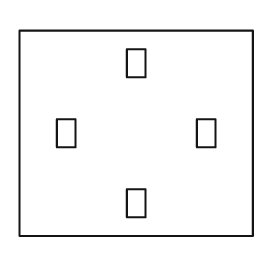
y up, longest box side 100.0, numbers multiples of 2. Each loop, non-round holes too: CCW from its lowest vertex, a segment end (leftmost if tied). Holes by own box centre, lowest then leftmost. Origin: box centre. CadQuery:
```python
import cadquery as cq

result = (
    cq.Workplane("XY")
    .moveTo(-50.0, -44.0)
    .lineTo(50.0, -44.0)
    .lineTo(50.0, 44.0)
    .lineTo(-50.0, 44.0)
    .close()
    .moveTo(-4.0, -36.0)
    .lineTo(4.0, -36.0)
    .lineTo(4.0, -24.0)
    .lineTo(-4.0, -24.0)
    .close()
    .moveTo(-34.0, -6.0)
    .lineTo(-26.0, -6.0)
    .lineTo(-26.0, 6.0)
    .lineTo(-34.0, 6.0)
    .close()
    .moveTo(26.0, -6.0)
    .lineTo(34.0, -6.0)
    .lineTo(34.0, 6.0)
    .lineTo(26.0, 6.0)
    .close()
    .moveTo(-4.0, 24.0)
    .lineTo(4.0, 24.0)
    .lineTo(4.0, 36.0)
    .lineTo(-4.0, 36.0)
    .close()
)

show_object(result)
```